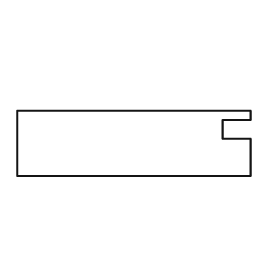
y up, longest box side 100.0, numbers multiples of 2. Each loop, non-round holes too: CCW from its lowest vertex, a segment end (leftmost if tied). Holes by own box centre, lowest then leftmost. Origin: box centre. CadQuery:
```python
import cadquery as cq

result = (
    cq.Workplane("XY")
    .moveTo(-50.0, -14.0)
    .lineTo(50.0, -14.0)
    .lineTo(50.0, 2.0)
    .lineTo(38.0, 2.0)
    .lineTo(38.0, 10.0)
    .lineTo(50.0, 10.0)
    .lineTo(50.0, 14.0)
    .lineTo(-50.0, 14.0)
    .close()
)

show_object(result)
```